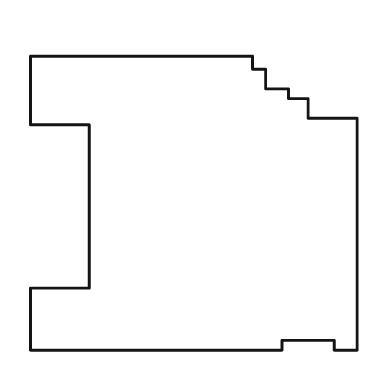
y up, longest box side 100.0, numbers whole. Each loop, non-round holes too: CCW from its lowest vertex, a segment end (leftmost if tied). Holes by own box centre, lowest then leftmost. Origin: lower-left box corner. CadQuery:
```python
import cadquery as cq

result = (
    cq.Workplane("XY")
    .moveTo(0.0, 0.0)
    .lineTo(77.0, 0.0)
    .lineTo(77.0, 3.0)
    .lineTo(93.0, 3.0)
    .lineTo(93.0, 0.0)
    .lineTo(100.0, 0.0)
    .lineTo(100.0, 71.0)
    .lineTo(85.0, 71.0)
    .lineTo(85.0, 77.0)
    .lineTo(79.0, 77.0)
    .lineTo(79.0, 80.0)
    .lineTo(72.0, 80.0)
    .lineTo(72.0, 86.0)
    .lineTo(68.0, 86.0)
    .lineTo(68.0, 90.0)
    .lineTo(0.0, 90.0)
    .lineTo(0.0, 69.0)
    .lineTo(18.0, 69.0)
    .lineTo(18.0, 19.0)
    .lineTo(0.0, 19.0)
    .close()
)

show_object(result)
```